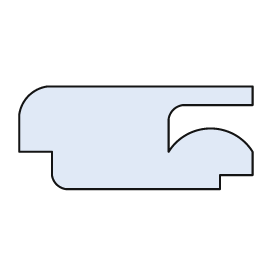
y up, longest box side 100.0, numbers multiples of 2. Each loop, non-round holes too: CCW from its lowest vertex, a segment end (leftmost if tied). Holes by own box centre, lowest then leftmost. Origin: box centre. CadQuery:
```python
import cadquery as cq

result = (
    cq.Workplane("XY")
    .moveTo(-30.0, -22.0)
    .lineTo(36.0, -22.0)
    .lineTo(36.0, -16.0)
    .lineTo(50.0, -16.0)
    .lineTo(50.0, -6.0)
    .threePointArc((32.0, 4.0), (14.0, -6.0))
    .lineTo(14.0, 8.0)
    .threePointArc((16.0, 12.0), (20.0, 14.0))
    .lineTo(50.0, 14.0)
    .lineTo(50.0, 22.0)
    .lineTo(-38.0, 22.0)
    .threePointArc((-46.0, 18.0), (-50.0, 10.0))
    .lineTo(-50.0, -6.0)
    .lineTo(-36.0, -6.0)
    .lineTo(-36.0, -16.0)
    .threePointArc((-34.0, -20.0), (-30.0, -22.0))
    .close()
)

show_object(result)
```